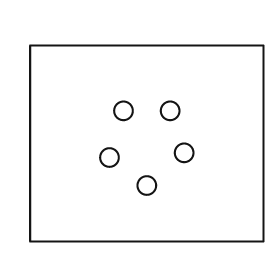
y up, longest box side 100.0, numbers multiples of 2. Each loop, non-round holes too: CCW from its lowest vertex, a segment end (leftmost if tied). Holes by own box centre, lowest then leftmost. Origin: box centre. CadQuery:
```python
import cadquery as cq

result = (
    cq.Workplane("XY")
    .moveTo(-50.0, -42.0)
    .lineTo(50.0, -42.0)
    .lineTo(50.0, 42.0)
    .lineTo(-50.0, 42.0)
    .close()
    .moveTo(0.0, -18.0)
    .circle(4.0)
    .moveTo(-16.0, -6.0)
    .circle(4.0)
    .moveTo(16.0, -4.0)
    .circle(4.0)
    .moveTo(-10.0, 14.0)
    .circle(4.0)
    .moveTo(10.0, 14.0)
    .circle(4.0)
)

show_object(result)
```